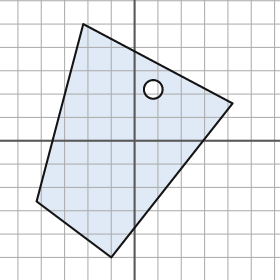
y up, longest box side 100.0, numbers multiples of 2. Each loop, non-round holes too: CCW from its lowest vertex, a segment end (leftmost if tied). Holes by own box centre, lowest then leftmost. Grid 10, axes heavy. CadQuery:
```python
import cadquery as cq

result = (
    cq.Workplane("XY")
    .moveTo(-10.0, -50.0)
    .lineTo(42.0, 16.0)
    .lineTo(-22.0, 50.0)
    .lineTo(-42.0, -26.0)
    .close()
    .moveTo(8.0, 22.0)
    .circle(4.0)
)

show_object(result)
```